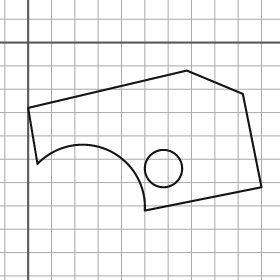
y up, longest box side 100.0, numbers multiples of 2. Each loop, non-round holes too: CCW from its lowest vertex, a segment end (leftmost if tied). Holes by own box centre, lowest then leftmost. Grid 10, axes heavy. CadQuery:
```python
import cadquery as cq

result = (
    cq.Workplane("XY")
    .moveTo(50.0, -72.0)
    .lineTo(100.0, -62.0)
    .lineTo(92.0, -22.0)
    .lineTo(68.0, -12.0)
    .lineTo(0.0, -28.0)
    .lineTo(4.0, -52.0)
    .threePointArc((34.0, -46.0), (50.0, -72.0))
    .close()
    .moveTo(58.0, -54.0)
    .circle(8.0)
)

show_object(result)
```